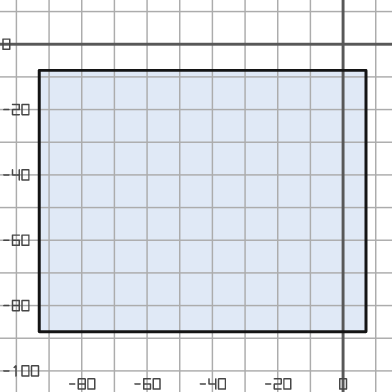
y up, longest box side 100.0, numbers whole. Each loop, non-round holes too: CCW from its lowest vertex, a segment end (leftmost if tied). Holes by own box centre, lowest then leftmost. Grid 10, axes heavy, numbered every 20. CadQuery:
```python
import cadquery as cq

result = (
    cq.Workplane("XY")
    .moveTo(-93.0, -88.0)
    .lineTo(7.0, -88.0)
    .lineTo(7.0, -8.0)
    .lineTo(-93.0, -8.0)
    .close()
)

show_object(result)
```